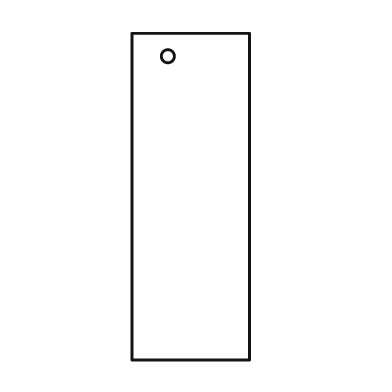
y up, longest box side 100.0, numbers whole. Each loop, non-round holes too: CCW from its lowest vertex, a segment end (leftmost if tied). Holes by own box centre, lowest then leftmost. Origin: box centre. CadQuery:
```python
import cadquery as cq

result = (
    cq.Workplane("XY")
    .moveTo(-18.0, -50.0)
    .lineTo(18.0, -50.0)
    .lineTo(18.0, 50.0)
    .lineTo(-18.0, 50.0)
    .close()
    .moveTo(-7.0, 43.0)
    .circle(2.0)
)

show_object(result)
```